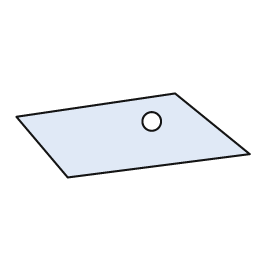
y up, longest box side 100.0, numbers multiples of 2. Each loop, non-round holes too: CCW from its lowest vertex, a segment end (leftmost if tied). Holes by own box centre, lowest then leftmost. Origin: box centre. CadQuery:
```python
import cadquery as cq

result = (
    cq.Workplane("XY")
    .moveTo(-28.0, -18.0)
    .lineTo(50.0, -8.0)
    .lineTo(18.0, 18.0)
    .lineTo(-50.0, 8.0)
    .close()
    .moveTo(8.0, 6.0)
    .circle(4.0)
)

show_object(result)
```